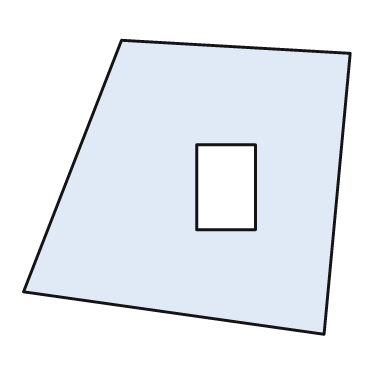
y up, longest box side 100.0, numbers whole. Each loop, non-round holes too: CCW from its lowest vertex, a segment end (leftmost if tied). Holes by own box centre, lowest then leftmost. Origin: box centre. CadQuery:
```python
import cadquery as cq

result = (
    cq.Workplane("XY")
    .moveTo(42.0, -45.0)
    .lineTo(50.0, 41.0)
    .lineTo(-20.0, 45.0)
    .lineTo(-50.0, -32.0)
    .close()
    .moveTo(3.0, -13.0)
    .lineTo(21.0, -13.0)
    .lineTo(21.0, 13.0)
    .lineTo(3.0, 13.0)
    .close()
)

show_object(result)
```